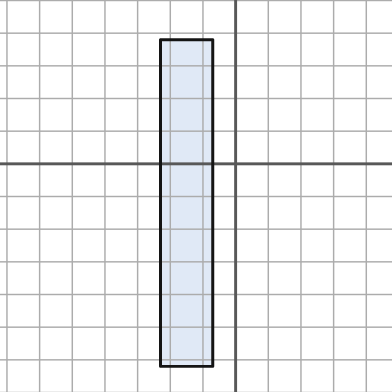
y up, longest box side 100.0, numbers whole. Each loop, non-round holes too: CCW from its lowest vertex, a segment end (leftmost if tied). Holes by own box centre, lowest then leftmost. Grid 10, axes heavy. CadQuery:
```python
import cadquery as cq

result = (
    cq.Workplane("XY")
    .moveTo(-23.0, -62.0)
    .lineTo(-7.0, -62.0)
    .lineTo(-7.0, 38.0)
    .lineTo(-23.0, 38.0)
    .close()
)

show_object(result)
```